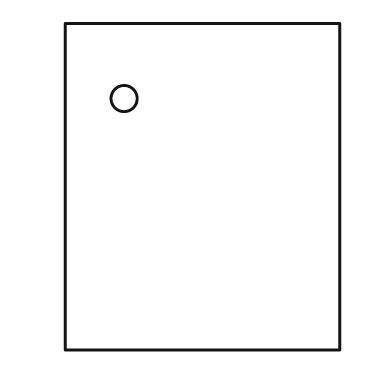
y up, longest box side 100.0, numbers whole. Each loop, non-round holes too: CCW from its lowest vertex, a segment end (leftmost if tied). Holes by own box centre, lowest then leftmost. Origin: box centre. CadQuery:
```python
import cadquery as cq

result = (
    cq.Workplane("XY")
    .moveTo(-42.0, -50.0)
    .lineTo(42.0, -50.0)
    .lineTo(42.0, 50.0)
    .lineTo(-42.0, 50.0)
    .close()
    .moveTo(-24.0, 27.0)
    .circle(4.0)
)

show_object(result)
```